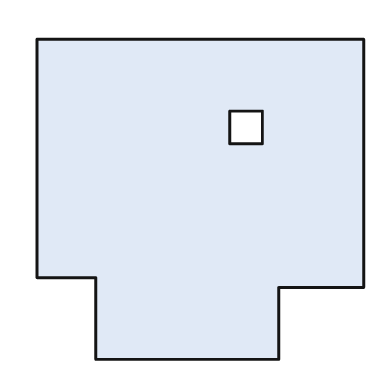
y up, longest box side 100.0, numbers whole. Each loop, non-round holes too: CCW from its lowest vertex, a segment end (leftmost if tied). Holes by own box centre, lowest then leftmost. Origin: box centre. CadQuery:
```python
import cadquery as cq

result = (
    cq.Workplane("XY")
    .moveTo(-32.0, -49.0)
    .lineTo(24.0, -49.0)
    .lineTo(24.0, -27.0)
    .lineTo(50.0, -27.0)
    .lineTo(50.0, 49.0)
    .lineTo(-50.0, 49.0)
    .lineTo(-50.0, -24.0)
    .lineTo(-32.0, -24.0)
    .close()
    .moveTo(9.0, 17.0)
    .lineTo(19.0, 17.0)
    .lineTo(19.0, 27.0)
    .lineTo(9.0, 27.0)
    .close()
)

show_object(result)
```